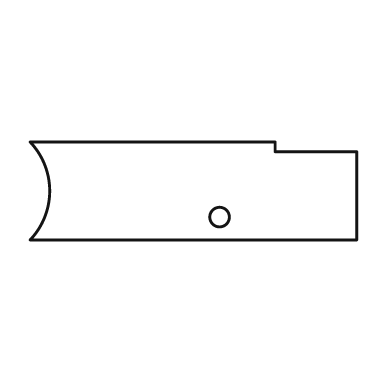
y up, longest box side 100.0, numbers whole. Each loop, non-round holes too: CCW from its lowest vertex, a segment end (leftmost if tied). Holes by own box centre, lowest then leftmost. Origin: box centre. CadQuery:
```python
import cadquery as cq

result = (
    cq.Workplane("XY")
    .moveTo(-50.0, -15.0)
    .lineTo(50.0, -15.0)
    .lineTo(50.0, 12.0)
    .lineTo(25.0, 12.0)
    .lineTo(25.0, 15.0)
    .lineTo(-50.0, 15.0)
    .threePointArc((-44.0, 0.0), (-50.0, -15.0))
    .close()
    .moveTo(8.0, -8.0)
    .circle(3.0)
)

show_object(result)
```